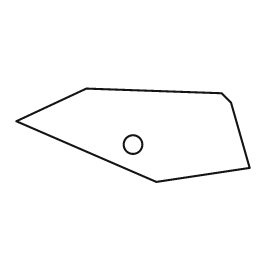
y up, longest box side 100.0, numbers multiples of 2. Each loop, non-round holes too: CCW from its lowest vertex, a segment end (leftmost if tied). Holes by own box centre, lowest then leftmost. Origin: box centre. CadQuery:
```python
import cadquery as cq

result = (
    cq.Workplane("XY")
    .moveTo(10.0, -20.0)
    .lineTo(50.0, -14.0)
    .lineTo(42.0, 14.0)
    .lineTo(38.0, 18.0)
    .lineTo(-20.0, 20.0)
    .lineTo(-50.0, 6.0)
    .close()
    .moveTo(0.0, -4.0)
    .circle(4.0)
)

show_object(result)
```